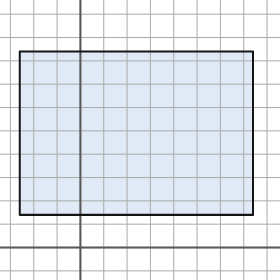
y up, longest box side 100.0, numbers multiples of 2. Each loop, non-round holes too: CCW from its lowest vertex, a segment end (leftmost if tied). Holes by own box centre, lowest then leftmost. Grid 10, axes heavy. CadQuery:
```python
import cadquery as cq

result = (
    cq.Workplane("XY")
    .moveTo(-26.0, 14.0)
    .lineTo(74.0, 14.0)
    .lineTo(74.0, 84.0)
    .lineTo(-26.0, 84.0)
    .close()
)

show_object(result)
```